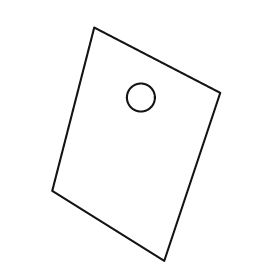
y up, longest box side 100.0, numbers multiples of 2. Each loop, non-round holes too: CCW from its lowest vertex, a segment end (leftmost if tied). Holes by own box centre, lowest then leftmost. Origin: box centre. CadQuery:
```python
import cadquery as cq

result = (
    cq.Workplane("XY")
    .moveTo(12.0, -50.0)
    .lineTo(36.0, 22.0)
    .lineTo(-18.0, 50.0)
    .lineTo(-36.0, -20.0)
    .close()
    .moveTo(2.0, 20.0)
    .circle(6.0)
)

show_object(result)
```